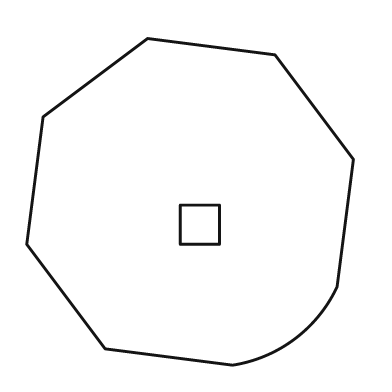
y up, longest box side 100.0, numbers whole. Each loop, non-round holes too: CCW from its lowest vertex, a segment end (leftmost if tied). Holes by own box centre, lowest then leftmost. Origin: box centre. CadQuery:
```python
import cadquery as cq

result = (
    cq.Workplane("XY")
    .moveTo(13.0, -50.0)
    .threePointArc((32.0, -42.0), (45.0, -26.0))
    .lineTo(50.0, 13.0)
    .lineTo(26.0, 45.0)
    .lineTo(-13.0, 50.0)
    .lineTo(-45.0, 26.0)
    .lineTo(-50.0, -13.0)
    .lineTo(-26.0, -45.0)
    .close()
    .moveTo(-3.0, -13.0)
    .lineTo(9.0, -13.0)
    .lineTo(9.0, -1.0)
    .lineTo(-3.0, -1.0)
    .close()
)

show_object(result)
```